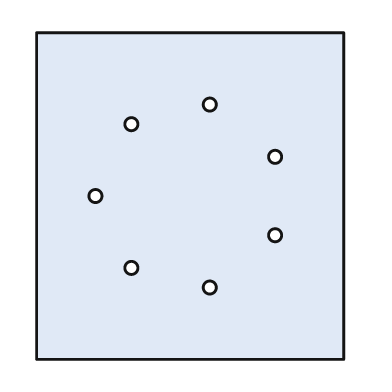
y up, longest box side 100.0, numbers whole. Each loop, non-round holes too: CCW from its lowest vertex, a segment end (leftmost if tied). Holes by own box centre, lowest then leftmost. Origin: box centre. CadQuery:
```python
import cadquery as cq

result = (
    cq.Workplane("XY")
    .moveTo(-47.0, -50.0)
    .lineTo(47.0, -50.0)
    .lineTo(47.0, 50.0)
    .lineTo(-47.0, 50.0)
    .close()
    .moveTo(6.0, -28.0)
    .circle(2.0)
    .moveTo(-18.0, -22.0)
    .circle(2.0)
    .moveTo(26.0, -12.0)
    .circle(2.0)
    .moveTo(-29.0, 0.0)
    .circle(2.0)
    .moveTo(26.0, 12.0)
    .circle(2.0)
    .moveTo(-18.0, 22.0)
    .circle(2.0)
    .moveTo(6.0, 28.0)
    .circle(2.0)
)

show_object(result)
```